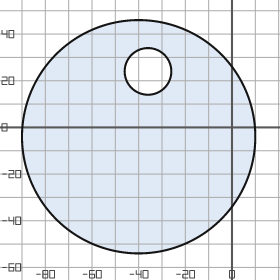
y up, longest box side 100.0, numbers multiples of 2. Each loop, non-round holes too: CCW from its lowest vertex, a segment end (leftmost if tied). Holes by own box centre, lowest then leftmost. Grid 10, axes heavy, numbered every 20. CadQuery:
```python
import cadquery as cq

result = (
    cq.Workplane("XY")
    .moveTo(-40.0, -4.0)
    .circle(50.0)
    .moveTo(-36.0, 24.0)
    .circle(10.0)
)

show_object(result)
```